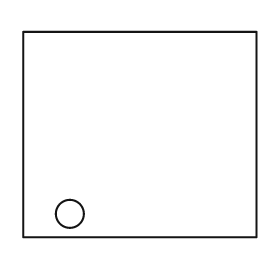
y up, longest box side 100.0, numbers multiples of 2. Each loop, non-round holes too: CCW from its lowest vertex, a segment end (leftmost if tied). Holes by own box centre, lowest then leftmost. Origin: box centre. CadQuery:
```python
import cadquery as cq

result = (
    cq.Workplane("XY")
    .moveTo(-50.0, -44.0)
    .lineTo(50.0, -44.0)
    .lineTo(50.0, 44.0)
    .lineTo(-50.0, 44.0)
    .close()
    .moveTo(-30.0, -34.0)
    .circle(6.0)
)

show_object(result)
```